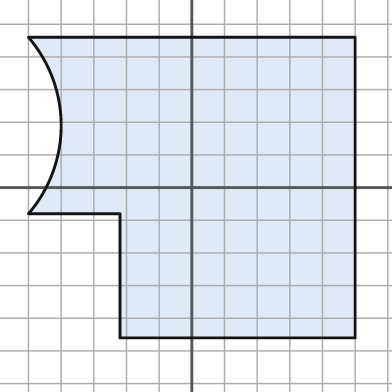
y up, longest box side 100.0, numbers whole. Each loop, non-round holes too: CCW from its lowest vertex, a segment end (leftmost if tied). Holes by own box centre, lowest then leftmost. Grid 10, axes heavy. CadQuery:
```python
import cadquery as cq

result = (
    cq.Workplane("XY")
    .moveTo(-22.0, -46.0)
    .lineTo(50.0, -46.0)
    .lineTo(50.0, 46.0)
    .lineTo(-50.0, 46.0)
    .threePointArc((-40.0, 19.0), (-50.0, -8.0))
    .lineTo(-22.0, -8.0)
    .close()
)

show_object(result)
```